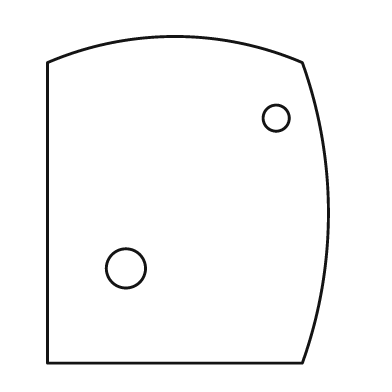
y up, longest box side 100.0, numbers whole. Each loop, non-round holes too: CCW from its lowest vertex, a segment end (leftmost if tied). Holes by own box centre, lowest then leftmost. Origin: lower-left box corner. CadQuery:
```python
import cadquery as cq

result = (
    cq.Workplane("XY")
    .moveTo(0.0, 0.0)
    .lineTo(78.0, 0.0)
    .threePointArc((86.0, 46.0), (78.0, 92.0))
    .threePointArc((39.0, 100.0), (0.0, 92.0))
    .close()
    .moveTo(24.0, 29.0)
    .circle(6.0)
    .moveTo(70.0, 75.0)
    .circle(4.0)
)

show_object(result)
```